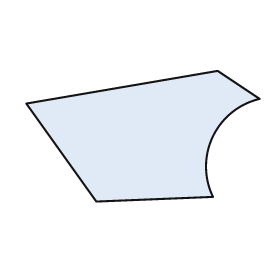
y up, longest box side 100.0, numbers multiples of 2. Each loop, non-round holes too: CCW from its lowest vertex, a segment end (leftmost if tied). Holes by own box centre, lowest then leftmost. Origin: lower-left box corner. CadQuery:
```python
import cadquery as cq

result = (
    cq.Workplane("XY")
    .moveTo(30.0, 0.0)
    .lineTo(80.0, 2.0)
    .threePointArc((80.0, 28.0), (100.0, 44.0))
    .lineTo(82.0, 56.0)
    .lineTo(0.0, 42.0)
    .close()
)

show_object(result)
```